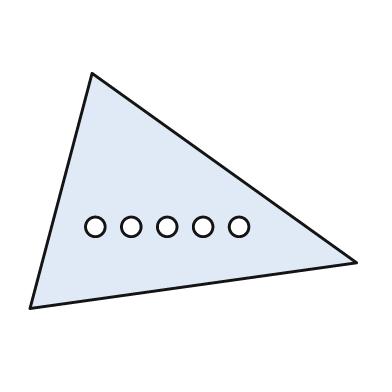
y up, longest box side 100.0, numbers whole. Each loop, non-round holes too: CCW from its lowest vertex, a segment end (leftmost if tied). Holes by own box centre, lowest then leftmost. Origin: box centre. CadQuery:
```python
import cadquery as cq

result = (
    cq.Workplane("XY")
    .moveTo(-50.0, -36.0)
    .lineTo(50.0, -22.0)
    .lineTo(-31.0, 36.0)
    .close()
    .moveTo(-30.0, -11.0)
    .circle(3.0)
    .moveTo(-19.0, -11.0)
    .circle(3.0)
    .moveTo(-8.0, -11.0)
    .circle(3.0)
    .moveTo(3.0, -11.0)
    .circle(3.0)
    .moveTo(14.0, -11.0)
    .circle(3.0)
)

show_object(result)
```